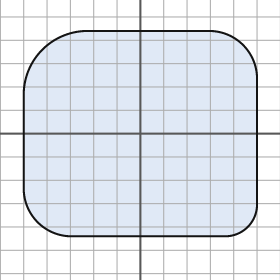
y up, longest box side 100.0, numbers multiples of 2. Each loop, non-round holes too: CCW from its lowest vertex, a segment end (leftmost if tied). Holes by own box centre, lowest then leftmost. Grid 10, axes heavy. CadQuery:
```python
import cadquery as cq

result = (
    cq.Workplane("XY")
    .moveTo(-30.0, -44.0)
    .lineTo(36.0, -44.0)
    .threePointArc((46.0, -40.0), (50.0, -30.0))
    .lineTo(50.0, 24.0)
    .threePointArc((44.0, 38.0), (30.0, 44.0))
    .lineTo(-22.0, 44.0)
    .threePointArc((-42.0, 36.0), (-50.0, 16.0))
    .lineTo(-50.0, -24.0)
    .threePointArc((-44.0, -38.0), (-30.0, -44.0))
    .close()
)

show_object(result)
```